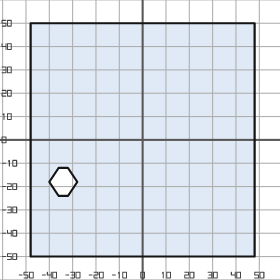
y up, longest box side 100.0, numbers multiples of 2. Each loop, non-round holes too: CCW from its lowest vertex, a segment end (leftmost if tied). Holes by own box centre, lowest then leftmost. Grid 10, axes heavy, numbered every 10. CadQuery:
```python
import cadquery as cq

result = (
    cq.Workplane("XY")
    .moveTo(-48.0, -50.0)
    .lineTo(48.0, -50.0)
    .lineTo(48.0, 50.0)
    .lineTo(-48.0, 50.0)
    .close()
    .moveTo(-36.0, -24.0)
    .lineTo(-32.0, -24.0)
    .lineTo(-28.0, -18.0)
    .lineTo(-32.0, -12.0)
    .lineTo(-36.0, -12.0)
    .lineTo(-40.0, -18.0)
    .close()
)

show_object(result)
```